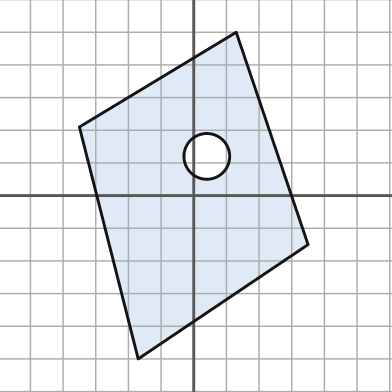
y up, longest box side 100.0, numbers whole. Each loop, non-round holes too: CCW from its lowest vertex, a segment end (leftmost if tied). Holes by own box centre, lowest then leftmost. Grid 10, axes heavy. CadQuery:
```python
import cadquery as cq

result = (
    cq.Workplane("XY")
    .moveTo(-17.0, -50.0)
    .lineTo(35.0, -15.0)
    .lineTo(13.0, 50.0)
    .lineTo(-35.0, 21.0)
    .close()
    .moveTo(4.0, 12.0)
    .circle(7.0)
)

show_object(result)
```